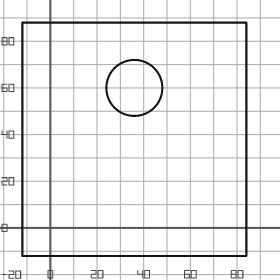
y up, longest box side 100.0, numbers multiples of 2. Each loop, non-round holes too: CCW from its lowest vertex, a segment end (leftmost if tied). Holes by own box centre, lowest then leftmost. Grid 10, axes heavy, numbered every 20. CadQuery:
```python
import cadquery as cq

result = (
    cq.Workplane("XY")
    .moveTo(-12.0, -12.0)
    .lineTo(84.0, -12.0)
    .lineTo(84.0, 88.0)
    .lineTo(-12.0, 88.0)
    .close()
    .moveTo(36.0, 60.0)
    .circle(12.0)
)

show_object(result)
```